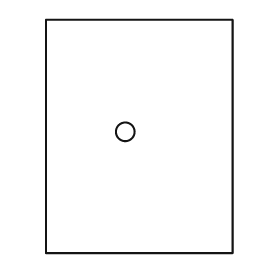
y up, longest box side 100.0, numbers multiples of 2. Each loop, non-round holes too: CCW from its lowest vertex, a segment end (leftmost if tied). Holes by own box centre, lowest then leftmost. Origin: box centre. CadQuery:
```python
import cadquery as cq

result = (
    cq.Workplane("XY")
    .moveTo(-40.0, -50.0)
    .lineTo(40.0, -50.0)
    .lineTo(40.0, 50.0)
    .lineTo(-40.0, 50.0)
    .close()
    .moveTo(-6.0, 2.0)
    .circle(4.0)
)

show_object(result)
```